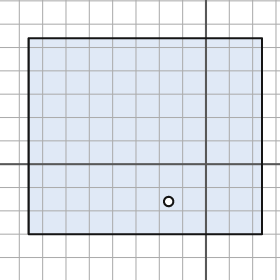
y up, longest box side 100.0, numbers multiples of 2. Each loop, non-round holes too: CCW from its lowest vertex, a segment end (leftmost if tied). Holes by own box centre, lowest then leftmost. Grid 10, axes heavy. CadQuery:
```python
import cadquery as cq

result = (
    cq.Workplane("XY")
    .moveTo(-76.0, -30.0)
    .lineTo(24.0, -30.0)
    .lineTo(24.0, 54.0)
    .lineTo(-76.0, 54.0)
    .close()
    .moveTo(-16.0, -16.0)
    .circle(2.0)
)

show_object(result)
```